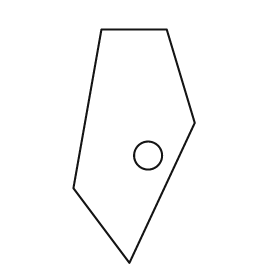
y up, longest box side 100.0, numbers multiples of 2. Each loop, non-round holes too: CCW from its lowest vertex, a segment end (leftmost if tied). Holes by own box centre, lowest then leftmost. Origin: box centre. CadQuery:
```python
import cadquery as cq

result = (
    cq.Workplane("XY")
    .moveTo(-2.0, -50.0)
    .lineTo(26.0, 10.0)
    .lineTo(14.0, 50.0)
    .lineTo(-14.0, 50.0)
    .lineTo(-26.0, -18.0)
    .close()
    .moveTo(6.0, -4.0)
    .circle(6.0)
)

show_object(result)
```